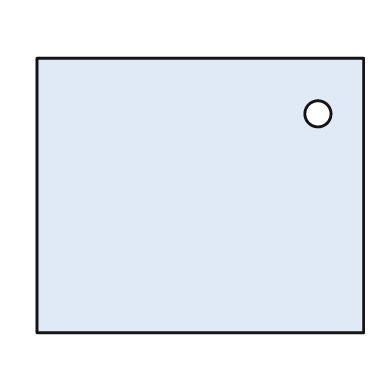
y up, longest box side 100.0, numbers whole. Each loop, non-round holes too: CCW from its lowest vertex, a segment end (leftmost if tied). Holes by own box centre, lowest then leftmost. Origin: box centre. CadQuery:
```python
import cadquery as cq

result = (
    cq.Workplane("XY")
    .moveTo(-50.0, -42.0)
    .lineTo(50.0, -42.0)
    .lineTo(50.0, 42.0)
    .lineTo(-50.0, 42.0)
    .close()
    .moveTo(36.0, 25.0)
    .circle(4.0)
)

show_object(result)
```